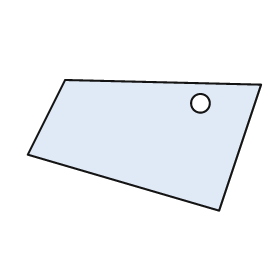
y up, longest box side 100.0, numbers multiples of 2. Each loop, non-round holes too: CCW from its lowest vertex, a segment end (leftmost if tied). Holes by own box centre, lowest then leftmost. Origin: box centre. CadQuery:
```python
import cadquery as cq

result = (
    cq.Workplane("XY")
    .moveTo(32.0, -28.0)
    .lineTo(50.0, 26.0)
    .lineTo(-34.0, 28.0)
    .lineTo(-50.0, -4.0)
    .close()
    .moveTo(24.0, 18.0)
    .circle(4.0)
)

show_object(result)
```